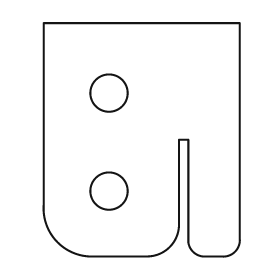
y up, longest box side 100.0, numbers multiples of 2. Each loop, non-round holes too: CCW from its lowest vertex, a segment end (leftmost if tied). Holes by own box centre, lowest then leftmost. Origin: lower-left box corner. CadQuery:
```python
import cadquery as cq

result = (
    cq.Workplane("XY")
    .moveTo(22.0, 0.0)
    .lineTo(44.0, 0.0)
    .threePointArc((54.0, 4.0), (58.0, 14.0))
    .lineTo(58.0, 50.0)
    .lineTo(62.0, 50.0)
    .lineTo(62.0, 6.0)
    .threePointArc((64.0, 2.0), (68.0, 0.0))
    .lineTo(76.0, 0.0)
    .threePointArc((82.0, 2.0), (84.0, 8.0))
    .lineTo(84.0, 100.0)
    .lineTo(0.0, 100.0)
    .lineTo(0.0, 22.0)
    .threePointArc((6.0, 6.0), (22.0, 0.0))
    .close()
    .moveTo(28.0, 28.0)
    .circle(8.0)
    .moveTo(28.0, 70.0)
    .circle(8.0)
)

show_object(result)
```